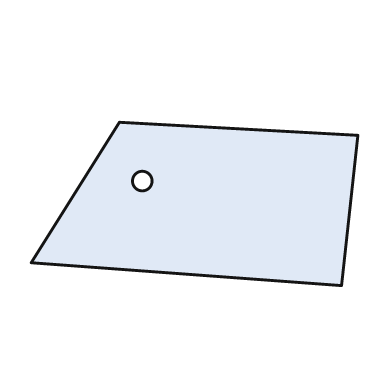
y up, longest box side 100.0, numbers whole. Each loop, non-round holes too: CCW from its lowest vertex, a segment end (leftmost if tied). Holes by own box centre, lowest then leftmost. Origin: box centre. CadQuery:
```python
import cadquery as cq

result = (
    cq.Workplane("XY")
    .moveTo(45.0, -25.0)
    .lineTo(50.0, 21.0)
    .lineTo(-23.0, 25.0)
    .lineTo(-50.0, -18.0)
    .close()
    .moveTo(-16.0, 7.0)
    .circle(3.0)
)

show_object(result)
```